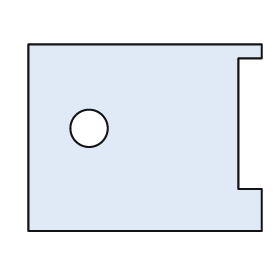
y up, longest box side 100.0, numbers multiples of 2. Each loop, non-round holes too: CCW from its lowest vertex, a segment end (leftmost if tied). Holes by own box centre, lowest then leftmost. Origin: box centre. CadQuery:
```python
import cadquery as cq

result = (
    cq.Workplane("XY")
    .moveTo(-50.0, -40.0)
    .lineTo(50.0, -40.0)
    .lineTo(50.0, -22.0)
    .lineTo(40.0, -22.0)
    .lineTo(40.0, 34.0)
    .lineTo(50.0, 34.0)
    .lineTo(50.0, 40.0)
    .lineTo(-50.0, 40.0)
    .close()
    .moveTo(-24.0, 4.0)
    .circle(8.0)
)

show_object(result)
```